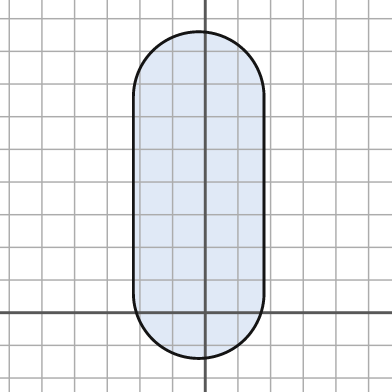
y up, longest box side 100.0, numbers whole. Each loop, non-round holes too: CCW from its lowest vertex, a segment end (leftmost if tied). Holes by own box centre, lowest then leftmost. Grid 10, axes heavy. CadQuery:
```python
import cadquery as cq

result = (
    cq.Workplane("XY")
    .moveTo(-22.0, 6.0)
    .threePointArc((-2.0, -14.0), (18.0, 6.0))
    .lineTo(18.0, 66.0)
    .threePointArc((-2.0, 86.0), (-22.0, 66.0))
    .close()
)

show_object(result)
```